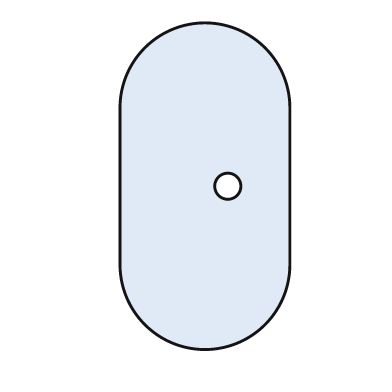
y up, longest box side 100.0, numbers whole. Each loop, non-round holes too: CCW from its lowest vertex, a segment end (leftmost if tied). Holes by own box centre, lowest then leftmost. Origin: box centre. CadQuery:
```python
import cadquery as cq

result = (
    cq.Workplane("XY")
    .moveTo(-26.0, -24.0)
    .threePointArc((0.0, -50.0), (26.0, -24.0))
    .lineTo(26.0, 24.0)
    .threePointArc((0.0, 50.0), (-26.0, 24.0))
    .close()
    .moveTo(7.0, 0.0)
    .circle(4.0)
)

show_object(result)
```